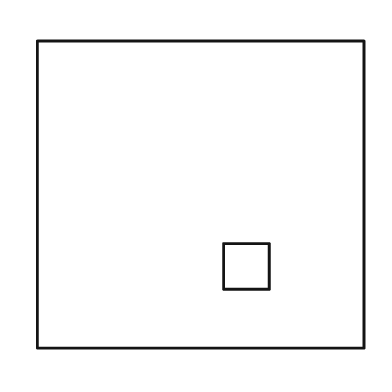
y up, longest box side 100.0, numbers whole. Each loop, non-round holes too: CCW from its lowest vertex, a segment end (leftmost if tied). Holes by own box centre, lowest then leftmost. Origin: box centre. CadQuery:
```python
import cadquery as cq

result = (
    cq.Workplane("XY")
    .moveTo(-50.0, -47.0)
    .lineTo(50.0, -47.0)
    .lineTo(50.0, 47.0)
    .lineTo(-50.0, 47.0)
    .close()
    .moveTo(7.0, -29.0)
    .lineTo(21.0, -29.0)
    .lineTo(21.0, -15.0)
    .lineTo(7.0, -15.0)
    .close()
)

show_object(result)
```